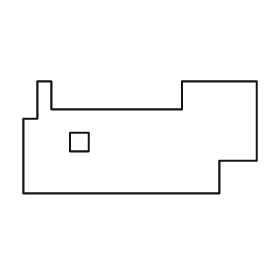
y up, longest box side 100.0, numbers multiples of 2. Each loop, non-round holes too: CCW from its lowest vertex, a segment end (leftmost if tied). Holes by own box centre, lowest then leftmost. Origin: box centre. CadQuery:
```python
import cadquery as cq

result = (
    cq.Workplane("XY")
    .moveTo(-50.0, -24.0)
    .lineTo(34.0, -24.0)
    .lineTo(34.0, -10.0)
    .lineTo(50.0, -10.0)
    .lineTo(50.0, 24.0)
    .lineTo(18.0, 24.0)
    .lineTo(18.0, 12.0)
    .lineTo(-38.0, 12.0)
    .lineTo(-38.0, 24.0)
    .lineTo(-44.0, 24.0)
    .lineTo(-44.0, 8.0)
    .lineTo(-50.0, 8.0)
    .close()
    .moveTo(-30.0, -6.0)
    .lineTo(-22.0, -6.0)
    .lineTo(-22.0, 2.0)
    .lineTo(-30.0, 2.0)
    .close()
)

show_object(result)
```